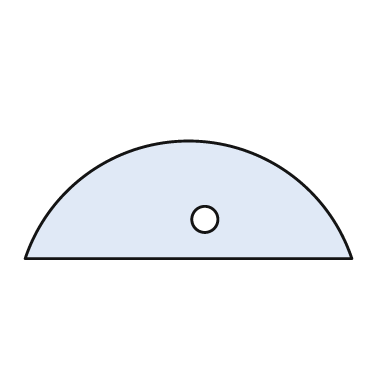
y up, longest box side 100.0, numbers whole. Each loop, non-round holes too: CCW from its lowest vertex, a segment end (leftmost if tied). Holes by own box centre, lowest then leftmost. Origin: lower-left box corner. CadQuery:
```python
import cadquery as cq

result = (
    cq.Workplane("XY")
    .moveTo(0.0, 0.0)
    .lineTo(100.0, 0.0)
    .threePointArc((50.0, 36.0), (0.0, 0.0))
    .close()
    .moveTo(55.0, 12.0)
    .circle(4.0)
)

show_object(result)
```